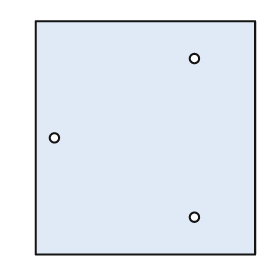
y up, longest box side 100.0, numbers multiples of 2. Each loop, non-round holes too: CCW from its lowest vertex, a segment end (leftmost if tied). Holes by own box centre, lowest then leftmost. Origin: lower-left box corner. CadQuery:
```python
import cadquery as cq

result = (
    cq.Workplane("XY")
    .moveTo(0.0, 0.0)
    .lineTo(94.0, 0.0)
    .lineTo(94.0, 100.0)
    .lineTo(0.0, 100.0)
    .close()
    .moveTo(68.0, 16.0)
    .circle(2.0)
    .moveTo(8.0, 50.0)
    .circle(2.0)
    .moveTo(68.0, 84.0)
    .circle(2.0)
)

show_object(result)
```